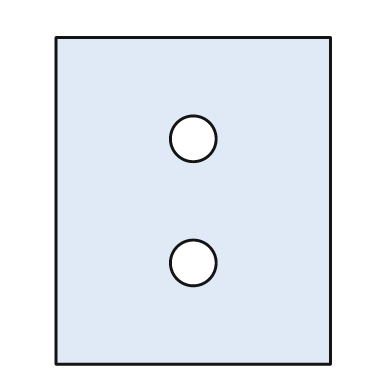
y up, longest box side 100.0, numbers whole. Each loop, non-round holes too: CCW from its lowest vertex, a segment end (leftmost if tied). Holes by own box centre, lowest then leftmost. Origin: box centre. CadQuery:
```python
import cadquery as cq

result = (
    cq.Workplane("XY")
    .moveTo(-42.0, -50.0)
    .lineTo(42.0, -50.0)
    .lineTo(42.0, 50.0)
    .lineTo(-42.0, 50.0)
    .close()
    .moveTo(0.0, -19.0)
    .circle(7.0)
    .moveTo(0.0, 19.0)
    .circle(7.0)
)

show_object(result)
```